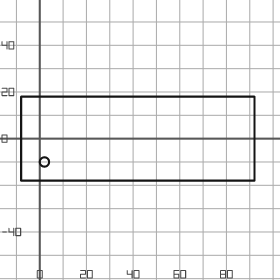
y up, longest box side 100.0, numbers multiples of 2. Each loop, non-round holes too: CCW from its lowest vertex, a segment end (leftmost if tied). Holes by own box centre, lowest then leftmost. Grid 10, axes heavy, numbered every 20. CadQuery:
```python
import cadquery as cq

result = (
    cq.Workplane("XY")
    .moveTo(-8.0, -18.0)
    .lineTo(92.0, -18.0)
    .lineTo(92.0, 18.0)
    .lineTo(-8.0, 18.0)
    .close()
    .moveTo(2.0, -10.0)
    .circle(2.0)
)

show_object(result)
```